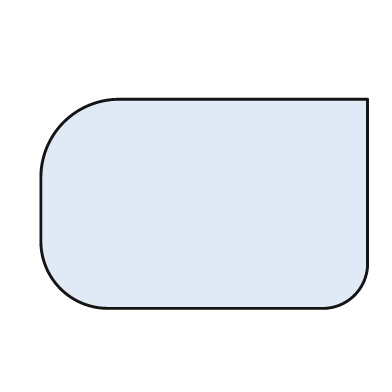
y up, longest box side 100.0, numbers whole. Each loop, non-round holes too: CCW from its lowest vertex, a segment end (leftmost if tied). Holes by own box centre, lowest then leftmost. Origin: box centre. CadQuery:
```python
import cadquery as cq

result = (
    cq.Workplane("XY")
    .moveTo(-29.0, -32.0)
    .lineTo(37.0, -32.0)
    .threePointArc((46.0, -28.0), (50.0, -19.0))
    .lineTo(50.0, 32.0)
    .lineTo(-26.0, 32.0)
    .threePointArc((-43.0, 25.0), (-50.0, 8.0))
    .lineTo(-50.0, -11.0)
    .threePointArc((-44.0, -26.0), (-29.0, -32.0))
    .close()
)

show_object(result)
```